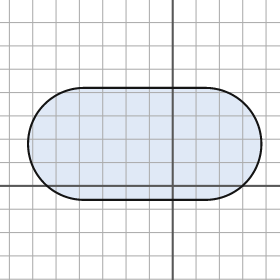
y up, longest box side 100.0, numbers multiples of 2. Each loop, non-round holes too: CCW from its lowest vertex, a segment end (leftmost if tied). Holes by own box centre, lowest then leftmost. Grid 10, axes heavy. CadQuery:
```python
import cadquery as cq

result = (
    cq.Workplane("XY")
    .moveTo(-38.0, -6.0)
    .lineTo(14.0, -6.0)
    .threePointArc((38.0, 18.0), (14.0, 42.0))
    .lineTo(-38.0, 42.0)
    .threePointArc((-62.0, 18.0), (-38.0, -6.0))
    .close()
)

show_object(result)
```